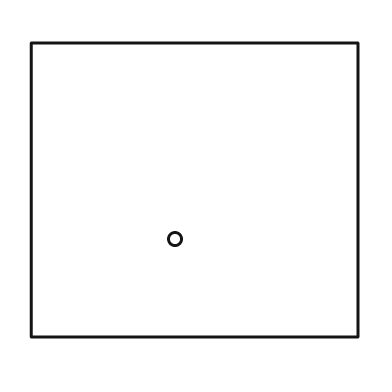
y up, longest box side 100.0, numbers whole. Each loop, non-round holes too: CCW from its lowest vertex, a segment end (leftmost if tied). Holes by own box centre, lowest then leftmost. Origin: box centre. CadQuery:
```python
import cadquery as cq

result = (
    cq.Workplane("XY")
    .moveTo(-50.0, -45.0)
    .lineTo(50.0, -45.0)
    .lineTo(50.0, 45.0)
    .lineTo(-50.0, 45.0)
    .close()
    .moveTo(-6.0, -15.0)
    .circle(2.0)
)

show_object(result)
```